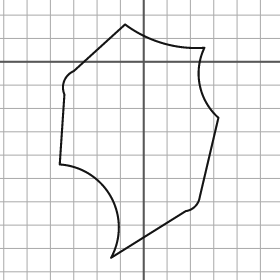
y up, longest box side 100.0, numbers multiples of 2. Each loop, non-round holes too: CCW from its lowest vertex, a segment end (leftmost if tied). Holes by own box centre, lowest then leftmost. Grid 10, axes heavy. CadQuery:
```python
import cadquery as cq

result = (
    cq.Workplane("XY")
    .moveTo(-14.0, -84.0)
    .lineTo(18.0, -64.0)
    .threePointArc((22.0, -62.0), (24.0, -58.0))
    .lineTo(32.0, -24.0)
    .threePointArc((24.0, -10.0), (26.0, 6.0))
    .threePointArc((8.0, 8.0), (-8.0, 16.0))
    .lineTo(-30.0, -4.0)
    .threePointArc((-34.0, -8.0), (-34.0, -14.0))
    .lineTo(-36.0, -44.0)
    .threePointArc((-14.0, -58.0), (-14.0, -84.0))
    .close()
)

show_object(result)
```